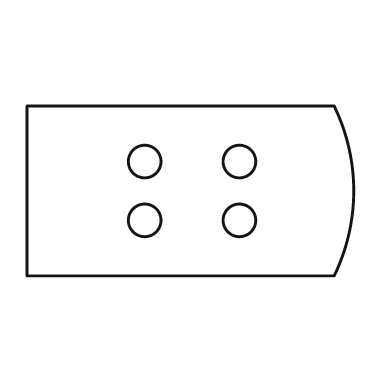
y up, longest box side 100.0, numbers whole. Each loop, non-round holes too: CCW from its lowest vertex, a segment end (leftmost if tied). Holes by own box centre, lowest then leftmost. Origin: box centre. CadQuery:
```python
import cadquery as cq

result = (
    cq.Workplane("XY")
    .moveTo(-50.0, -26.0)
    .lineTo(44.0, -26.0)
    .threePointArc((50.0, 0.0), (44.0, 26.0))
    .lineTo(-50.0, 26.0)
    .close()
    .moveTo(-14.0, -9.0)
    .circle(5.0)
    .moveTo(15.0, -9.0)
    .circle(5.0)
    .moveTo(-14.0, 9.0)
    .circle(5.0)
    .moveTo(15.0, 9.0)
    .circle(5.0)
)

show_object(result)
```